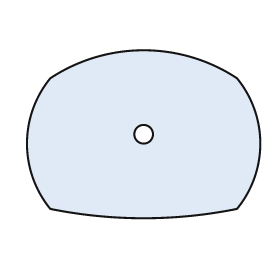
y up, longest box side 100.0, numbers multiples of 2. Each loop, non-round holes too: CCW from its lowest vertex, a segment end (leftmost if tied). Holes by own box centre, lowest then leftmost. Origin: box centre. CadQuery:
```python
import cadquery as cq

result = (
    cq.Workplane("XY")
    .moveTo(-40.0, -32.0)
    .threePointArc((0.0, -36.0), (40.0, -32.0))
    .threePointArc((50.0, -4.0), (40.0, 24.0))
    .threePointArc((0.0, 36.0), (-40.0, 24.0))
    .threePointArc((-50.0, -4.0), (-40.0, -32.0))
    .close()
    .moveTo(0.0, 0.0)
    .circle(4.0)
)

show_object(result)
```